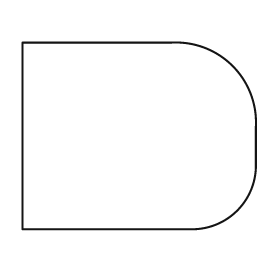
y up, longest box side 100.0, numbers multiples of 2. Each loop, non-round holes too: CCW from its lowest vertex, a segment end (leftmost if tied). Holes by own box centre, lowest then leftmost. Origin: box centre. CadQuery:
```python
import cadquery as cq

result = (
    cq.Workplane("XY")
    .moveTo(-50.0, -40.0)
    .lineTo(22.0, -40.0)
    .threePointArc((42.0, -32.0), (50.0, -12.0))
    .lineTo(50.0, 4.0)
    .threePointArc((40.0, 30.0), (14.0, 40.0))
    .lineTo(-50.0, 40.0)
    .close()
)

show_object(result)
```